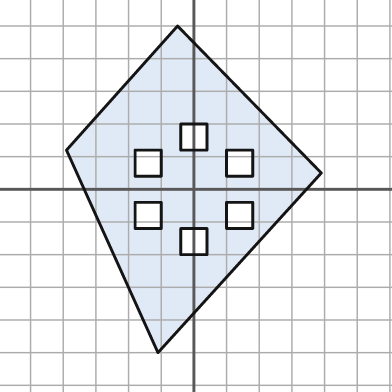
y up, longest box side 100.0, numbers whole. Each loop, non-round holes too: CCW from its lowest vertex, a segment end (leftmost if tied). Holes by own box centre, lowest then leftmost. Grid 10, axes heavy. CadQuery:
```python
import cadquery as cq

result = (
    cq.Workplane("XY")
    .moveTo(-11.0, -50.0)
    .lineTo(39.0, 5.0)
    .lineTo(-5.0, 50.0)
    .lineTo(-39.0, 12.0)
    .close()
    .moveTo(-4.0, -20.0)
    .lineTo(4.0, -20.0)
    .lineTo(4.0, -12.0)
    .lineTo(-4.0, -12.0)
    .close()
    .moveTo(-18.0, -12.0)
    .lineTo(-10.0, -12.0)
    .lineTo(-10.0, -4.0)
    .lineTo(-18.0, -4.0)
    .close()
    .moveTo(10.0, -12.0)
    .lineTo(18.0, -12.0)
    .lineTo(18.0, -4.0)
    .lineTo(10.0, -4.0)
    .close()
    .moveTo(-18.0, 4.0)
    .lineTo(-10.0, 4.0)
    .lineTo(-10.0, 12.0)
    .lineTo(-18.0, 12.0)
    .close()
    .moveTo(10.0, 4.0)
    .lineTo(18.0, 4.0)
    .lineTo(18.0, 12.0)
    .lineTo(10.0, 12.0)
    .close()
    .moveTo(-4.0, 12.0)
    .lineTo(4.0, 12.0)
    .lineTo(4.0, 20.0)
    .lineTo(-4.0, 20.0)
    .close()
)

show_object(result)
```